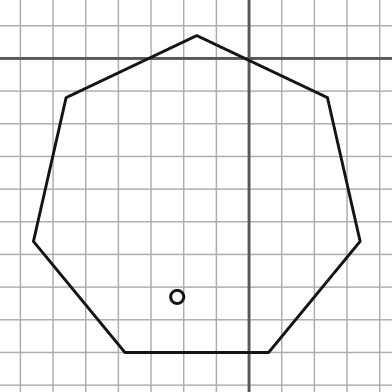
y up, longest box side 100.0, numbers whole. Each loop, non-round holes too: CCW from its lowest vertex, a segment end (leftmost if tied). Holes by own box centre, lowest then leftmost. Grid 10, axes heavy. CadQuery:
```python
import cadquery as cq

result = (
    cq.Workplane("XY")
    .moveTo(-38.0, -90.0)
    .lineTo(6.0, -90.0)
    .lineTo(34.0, -56.0)
    .lineTo(24.0, -12.0)
    .lineTo(-16.0, 7.0)
    .lineTo(-56.0, -12.0)
    .lineTo(-66.0, -56.0)
    .close()
    .moveTo(-22.0, -73.0)
    .circle(2.0)
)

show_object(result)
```